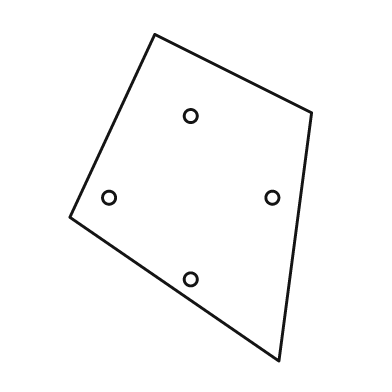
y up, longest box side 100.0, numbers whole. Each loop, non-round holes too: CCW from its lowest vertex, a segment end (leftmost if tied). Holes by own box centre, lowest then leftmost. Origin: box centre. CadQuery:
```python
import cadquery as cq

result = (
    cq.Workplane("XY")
    .moveTo(27.0, -50.0)
    .lineTo(37.0, 26.0)
    .lineTo(-11.0, 50.0)
    .lineTo(-37.0, -6.0)
    .close()
    .moveTo(0.0, -25.0)
    .circle(2.0)
    .moveTo(-25.0, 0.0)
    .circle(2.0)
    .moveTo(25.0, 0.0)
    .circle(2.0)
    .moveTo(0.0, 25.0)
    .circle(2.0)
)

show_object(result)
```